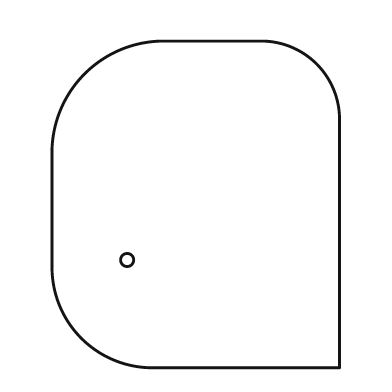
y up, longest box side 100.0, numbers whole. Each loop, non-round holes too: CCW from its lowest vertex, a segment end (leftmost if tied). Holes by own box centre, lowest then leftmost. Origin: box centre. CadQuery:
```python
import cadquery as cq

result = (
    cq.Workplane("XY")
    .moveTo(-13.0, -50.0)
    .lineTo(44.0, -50.0)
    .lineTo(44.0, 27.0)
    .threePointArc((37.0, 43.0), (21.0, 50.0))
    .lineTo(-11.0, 50.0)
    .threePointArc((-34.0, 40.0), (-44.0, 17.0))
    .lineTo(-44.0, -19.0)
    .threePointArc((-35.0, -41.0), (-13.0, -50.0))
    .close()
    .moveTo(-21.0, -17.0)
    .circle(2.0)
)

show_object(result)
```